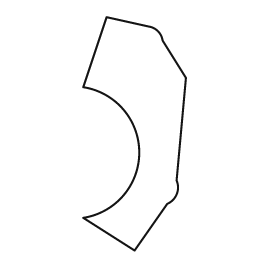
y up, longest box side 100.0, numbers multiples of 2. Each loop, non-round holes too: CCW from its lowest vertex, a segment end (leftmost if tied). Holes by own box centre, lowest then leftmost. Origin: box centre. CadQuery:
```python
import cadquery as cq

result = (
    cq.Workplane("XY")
    .moveTo(0.0, -50.0)
    .lineTo(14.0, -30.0)
    .threePointArc((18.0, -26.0), (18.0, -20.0))
    .lineTo(22.0, 24.0)
    .lineTo(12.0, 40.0)
    .threePointArc((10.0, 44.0), (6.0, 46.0))
    .lineTo(-12.0, 50.0)
    .lineTo(-22.0, 20.0)
    .threePointArc((2.0, -8.0), (-22.0, -36.0))
    .close()
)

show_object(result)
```